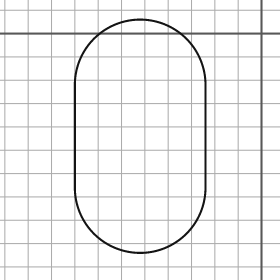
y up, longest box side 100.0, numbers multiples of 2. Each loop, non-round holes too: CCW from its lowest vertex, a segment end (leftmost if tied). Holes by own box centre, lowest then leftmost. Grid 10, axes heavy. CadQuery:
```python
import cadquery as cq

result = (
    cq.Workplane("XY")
    .moveTo(-80.0, -66.0)
    .threePointArc((-52.0, -94.0), (-24.0, -66.0))
    .lineTo(-24.0, -22.0)
    .threePointArc((-52.0, 6.0), (-80.0, -22.0))
    .close()
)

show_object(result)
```